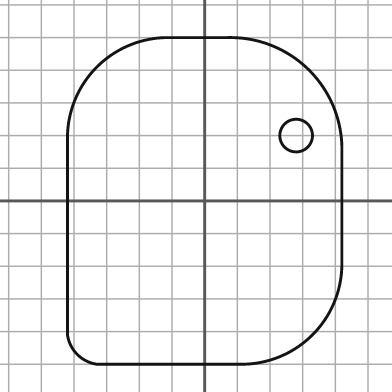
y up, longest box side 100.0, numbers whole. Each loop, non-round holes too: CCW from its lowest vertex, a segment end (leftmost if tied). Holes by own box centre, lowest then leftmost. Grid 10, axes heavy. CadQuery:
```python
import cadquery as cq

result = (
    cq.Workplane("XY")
    .moveTo(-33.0, -50.0)
    .lineTo(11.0, -50.0)
    .threePointArc((33.0, -41.0), (42.0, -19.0))
    .lineTo(42.0, 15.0)
    .threePointArc((32.0, 40.0), (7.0, 50.0))
    .lineTo(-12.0, 50.0)
    .threePointArc((-33.0, 41.0), (-42.0, 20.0))
    .lineTo(-42.0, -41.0)
    .threePointArc((-39.0, -47.0), (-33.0, -50.0))
    .close()
    .moveTo(28.0, 20.0)
    .circle(5.0)
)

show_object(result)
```